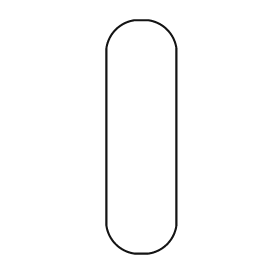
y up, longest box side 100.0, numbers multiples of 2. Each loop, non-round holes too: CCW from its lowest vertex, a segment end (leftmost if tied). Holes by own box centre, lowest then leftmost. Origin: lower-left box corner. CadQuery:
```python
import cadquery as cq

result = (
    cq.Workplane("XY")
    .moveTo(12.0, 0.0)
    .lineTo(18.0, 0.0)
    .threePointArc((26.0, 4.0), (30.0, 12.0))
    .lineTo(30.0, 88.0)
    .threePointArc((26.0, 96.0), (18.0, 100.0))
    .lineTo(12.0, 100.0)
    .threePointArc((4.0, 96.0), (0.0, 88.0))
    .lineTo(0.0, 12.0)
    .threePointArc((4.0, 4.0), (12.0, 0.0))
    .close()
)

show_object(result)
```